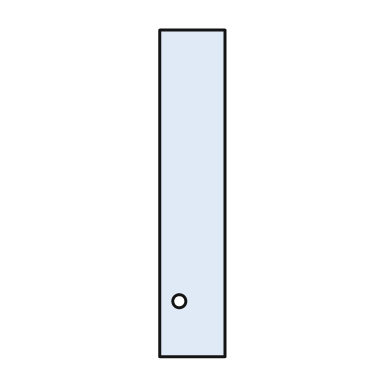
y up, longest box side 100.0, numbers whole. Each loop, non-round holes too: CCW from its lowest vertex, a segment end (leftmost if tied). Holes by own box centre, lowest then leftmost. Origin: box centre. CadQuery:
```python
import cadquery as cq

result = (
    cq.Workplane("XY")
    .moveTo(-10.0, -50.0)
    .lineTo(10.0, -50.0)
    .lineTo(10.0, 50.0)
    .lineTo(-10.0, 50.0)
    .close()
    .moveTo(-4.0, -33.0)
    .circle(2.0)
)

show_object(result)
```